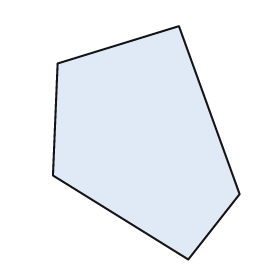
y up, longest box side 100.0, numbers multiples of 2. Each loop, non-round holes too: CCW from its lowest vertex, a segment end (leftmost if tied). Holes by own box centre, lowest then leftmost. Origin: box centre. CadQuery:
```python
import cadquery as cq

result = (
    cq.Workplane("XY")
    .moveTo(18.0, -50.0)
    .lineTo(40.0, -22.0)
    .lineTo(14.0, 50.0)
    .lineTo(-38.0, 34.0)
    .lineTo(-40.0, -14.0)
    .close()
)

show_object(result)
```